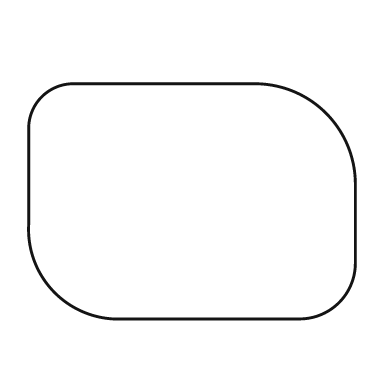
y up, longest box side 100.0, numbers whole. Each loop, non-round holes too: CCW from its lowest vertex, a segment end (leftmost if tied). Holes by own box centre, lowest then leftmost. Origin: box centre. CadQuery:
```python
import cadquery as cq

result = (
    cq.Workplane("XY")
    .moveTo(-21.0, -36.0)
    .lineTo(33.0, -36.0)
    .threePointArc((45.0, -31.0), (50.0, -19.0))
    .lineTo(50.0, 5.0)
    .threePointArc((41.0, 27.0), (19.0, 36.0))
    .lineTo(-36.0, 36.0)
    .threePointArc((-46.0, 32.0), (-50.0, 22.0))
    .lineTo(-50.0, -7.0)
    .threePointArc((-42.0, -28.0), (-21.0, -36.0))
    .close()
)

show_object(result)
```